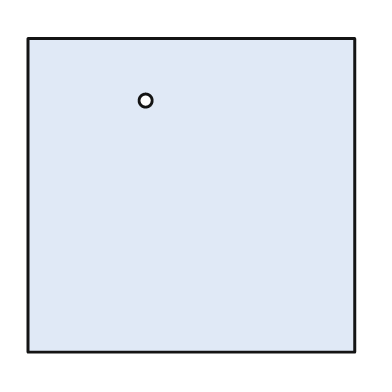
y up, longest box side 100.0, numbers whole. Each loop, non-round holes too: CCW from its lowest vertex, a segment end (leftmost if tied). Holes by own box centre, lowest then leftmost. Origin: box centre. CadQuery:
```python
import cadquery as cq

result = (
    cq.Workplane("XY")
    .moveTo(-50.0, -48.0)
    .lineTo(50.0, -48.0)
    .lineTo(50.0, 48.0)
    .lineTo(-50.0, 48.0)
    .close()
    .moveTo(-14.0, 29.0)
    .circle(2.0)
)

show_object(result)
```